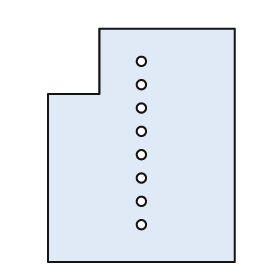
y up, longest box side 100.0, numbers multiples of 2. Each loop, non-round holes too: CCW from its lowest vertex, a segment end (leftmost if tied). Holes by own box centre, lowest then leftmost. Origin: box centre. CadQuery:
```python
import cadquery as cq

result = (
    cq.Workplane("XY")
    .moveTo(-40.0, -50.0)
    .lineTo(40.0, -50.0)
    .lineTo(40.0, 50.0)
    .lineTo(-18.0, 50.0)
    .lineTo(-18.0, 22.0)
    .lineTo(-40.0, 22.0)
    .close()
    .moveTo(0.0, -34.0)
    .circle(2.0)
    .moveTo(0.0, -24.0)
    .circle(2.0)
    .moveTo(0.0, -14.0)
    .circle(2.0)
    .moveTo(0.0, -4.0)
    .circle(2.0)
    .moveTo(0.0, 6.0)
    .circle(2.0)
    .moveTo(0.0, 16.0)
    .circle(2.0)
    .moveTo(0.0, 26.0)
    .circle(2.0)
    .moveTo(0.0, 36.0)
    .circle(2.0)
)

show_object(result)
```